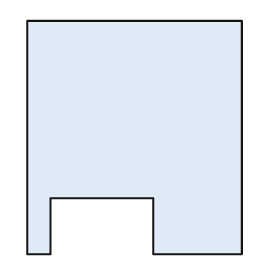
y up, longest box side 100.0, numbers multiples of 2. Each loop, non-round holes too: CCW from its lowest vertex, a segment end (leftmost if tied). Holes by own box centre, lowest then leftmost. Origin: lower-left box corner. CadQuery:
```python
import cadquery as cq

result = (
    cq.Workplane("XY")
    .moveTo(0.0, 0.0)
    .lineTo(10.0, 0.0)
    .lineTo(10.0, 24.0)
    .lineTo(54.0, 24.0)
    .lineTo(54.0, 0.0)
    .lineTo(92.0, 0.0)
    .lineTo(92.0, 100.0)
    .lineTo(0.0, 100.0)
    .close()
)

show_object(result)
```